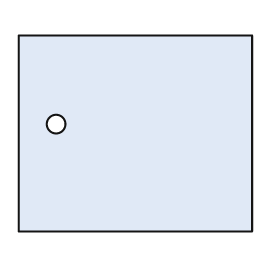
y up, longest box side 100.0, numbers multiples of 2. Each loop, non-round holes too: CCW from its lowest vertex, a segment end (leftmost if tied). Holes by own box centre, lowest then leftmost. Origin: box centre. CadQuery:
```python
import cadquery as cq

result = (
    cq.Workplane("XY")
    .moveTo(-50.0, -42.0)
    .lineTo(50.0, -42.0)
    .lineTo(50.0, 42.0)
    .lineTo(-50.0, 42.0)
    .close()
    .moveTo(-34.0, 4.0)
    .circle(4.0)
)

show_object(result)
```